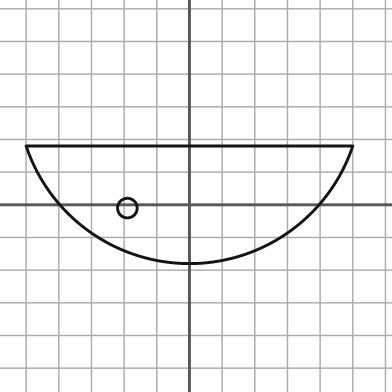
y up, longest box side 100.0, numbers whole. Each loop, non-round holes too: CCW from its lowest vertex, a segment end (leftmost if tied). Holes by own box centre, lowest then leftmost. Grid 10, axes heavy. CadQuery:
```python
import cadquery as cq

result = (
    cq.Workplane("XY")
    .moveTo(-50.0, 18.0)
    .threePointArc((0.0, -18.0), (50.0, 18.0))
    .close()
    .moveTo(-19.0, -1.0)
    .circle(3.0)
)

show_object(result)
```